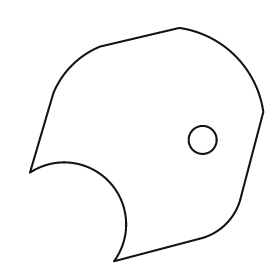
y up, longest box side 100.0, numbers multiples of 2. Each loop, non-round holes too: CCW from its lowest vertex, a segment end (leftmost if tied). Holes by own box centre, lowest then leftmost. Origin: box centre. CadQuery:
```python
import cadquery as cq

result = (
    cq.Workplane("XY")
    .moveTo(-14.0, -50.0)
    .lineTo(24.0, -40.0)
    .threePointArc((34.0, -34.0), (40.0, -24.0))
    .lineTo(50.0, 14.0)
    .threePointArc((38.0, 38.0), (14.0, 50.0))
    .lineTo(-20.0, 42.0)
    .threePointArc((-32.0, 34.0), (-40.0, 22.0))
    .lineTo(-50.0, -12.0)
    .threePointArc((-16.0, -16.0), (-14.0, -50.0))
    .close()
    .moveTo(24.0, 2.0)
    .circle(6.0)
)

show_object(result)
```